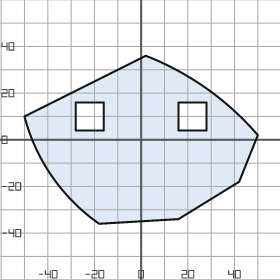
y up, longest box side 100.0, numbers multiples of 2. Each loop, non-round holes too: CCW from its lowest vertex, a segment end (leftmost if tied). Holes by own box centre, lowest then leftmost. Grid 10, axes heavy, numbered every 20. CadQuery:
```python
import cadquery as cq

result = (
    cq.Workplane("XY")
    .moveTo(-18.0, -36.0)
    .lineTo(16.0, -34.0)
    .lineTo(42.0, -18.0)
    .lineTo(50.0, 2.0)
    .threePointArc((28.0, 22.0), (2.0, 36.0))
    .lineTo(-50.0, 10.0)
    .threePointArc((-38.0, -16.0), (-18.0, -36.0))
    .close()
    .moveTo(-28.0, 4.0)
    .lineTo(-16.0, 4.0)
    .lineTo(-16.0, 16.0)
    .lineTo(-28.0, 16.0)
    .close()
    .moveTo(16.0, 4.0)
    .lineTo(28.0, 4.0)
    .lineTo(28.0, 16.0)
    .lineTo(16.0, 16.0)
    .close()
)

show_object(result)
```